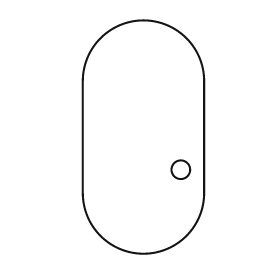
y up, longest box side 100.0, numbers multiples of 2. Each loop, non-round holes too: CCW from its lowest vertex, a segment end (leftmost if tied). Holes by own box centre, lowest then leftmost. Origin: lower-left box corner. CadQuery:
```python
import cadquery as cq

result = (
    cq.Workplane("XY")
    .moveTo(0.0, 26.0)
    .threePointArc((26.0, 0.0), (52.0, 26.0))
    .lineTo(52.0, 74.0)
    .threePointArc((26.0, 100.0), (0.0, 74.0))
    .close()
    .moveTo(42.0, 36.0)
    .circle(4.0)
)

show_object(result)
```